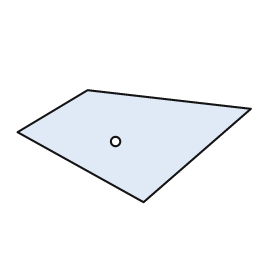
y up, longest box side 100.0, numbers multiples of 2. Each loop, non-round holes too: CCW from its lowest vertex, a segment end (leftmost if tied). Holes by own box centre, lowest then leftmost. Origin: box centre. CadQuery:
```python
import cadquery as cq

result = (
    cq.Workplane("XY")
    .moveTo(4.0, -24.0)
    .lineTo(50.0, 16.0)
    .lineTo(-20.0, 24.0)
    .lineTo(-50.0, 6.0)
    .close()
    .moveTo(-8.0, 2.0)
    .circle(2.0)
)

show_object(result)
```